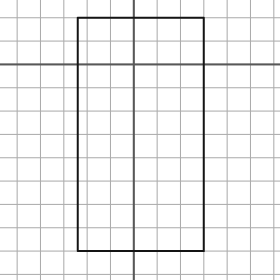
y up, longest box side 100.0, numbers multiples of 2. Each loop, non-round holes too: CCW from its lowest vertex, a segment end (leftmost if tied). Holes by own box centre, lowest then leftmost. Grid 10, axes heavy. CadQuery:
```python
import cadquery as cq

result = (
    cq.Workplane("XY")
    .moveTo(-24.0, -80.0)
    .lineTo(30.0, -80.0)
    .lineTo(30.0, 20.0)
    .lineTo(-24.0, 20.0)
    .close()
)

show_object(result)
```